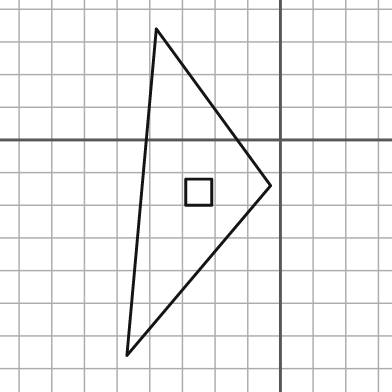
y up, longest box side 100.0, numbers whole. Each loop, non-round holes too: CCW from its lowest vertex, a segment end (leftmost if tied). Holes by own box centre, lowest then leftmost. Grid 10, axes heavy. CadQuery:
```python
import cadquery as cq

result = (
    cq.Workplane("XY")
    .moveTo(-47.0, -66.0)
    .lineTo(-3.0, -14.0)
    .lineTo(-38.0, 34.0)
    .close()
    .moveTo(-29.0, -20.0)
    .lineTo(-21.0, -20.0)
    .lineTo(-21.0, -12.0)
    .lineTo(-29.0, -12.0)
    .close()
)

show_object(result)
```